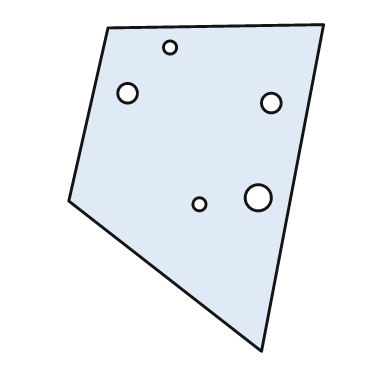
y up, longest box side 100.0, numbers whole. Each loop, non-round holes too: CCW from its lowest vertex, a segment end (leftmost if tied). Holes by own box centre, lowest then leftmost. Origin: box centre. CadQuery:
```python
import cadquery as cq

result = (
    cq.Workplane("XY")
    .moveTo(20.0, -50.0)
    .lineTo(39.0, 50.0)
    .lineTo(-27.0, 49.0)
    .lineTo(-39.0, -4.0)
    .close()
    .moveTo(1.0, -5.0)
    .circle(2.0)
    .moveTo(19.0, -3.0)
    .circle(4.0)
    .moveTo(23.0, 26.0)
    .circle(3.0)
    .moveTo(-21.0, 29.0)
    .circle(3.0)
    .moveTo(-8.0, 43.0)
    .circle(2.0)
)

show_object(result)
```